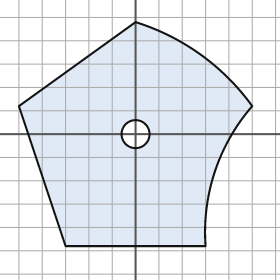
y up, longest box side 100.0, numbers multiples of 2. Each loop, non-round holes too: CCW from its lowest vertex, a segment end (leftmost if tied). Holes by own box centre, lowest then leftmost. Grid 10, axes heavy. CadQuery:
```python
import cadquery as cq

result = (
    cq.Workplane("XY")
    .moveTo(-30.0, -48.0)
    .lineTo(30.0, -48.0)
    .threePointArc((34.0, -16.0), (50.0, 12.0))
    .threePointArc((28.0, 34.0), (0.0, 48.0))
    .lineTo(-50.0, 12.0)
    .close()
    .moveTo(0.0, 0.0)
    .circle(6.0)
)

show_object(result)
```